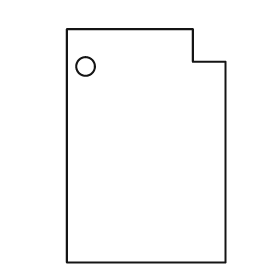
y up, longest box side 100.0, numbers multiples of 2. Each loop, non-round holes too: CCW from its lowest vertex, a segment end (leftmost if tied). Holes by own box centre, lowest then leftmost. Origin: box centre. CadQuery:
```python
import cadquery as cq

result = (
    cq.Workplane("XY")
    .moveTo(-34.0, -50.0)
    .lineTo(34.0, -50.0)
    .lineTo(34.0, 36.0)
    .lineTo(20.0, 36.0)
    .lineTo(20.0, 50.0)
    .lineTo(-34.0, 50.0)
    .close()
    .moveTo(-26.0, 34.0)
    .circle(4.0)
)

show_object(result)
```